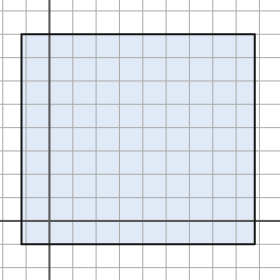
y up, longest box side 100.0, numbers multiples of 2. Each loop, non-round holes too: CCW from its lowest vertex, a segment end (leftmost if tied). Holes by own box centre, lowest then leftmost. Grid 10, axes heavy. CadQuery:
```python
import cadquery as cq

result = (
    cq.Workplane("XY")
    .moveTo(-12.0, -10.0)
    .lineTo(88.0, -10.0)
    .lineTo(88.0, 80.0)
    .lineTo(-12.0, 80.0)
    .close()
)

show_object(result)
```